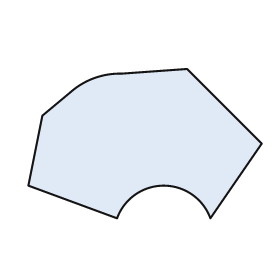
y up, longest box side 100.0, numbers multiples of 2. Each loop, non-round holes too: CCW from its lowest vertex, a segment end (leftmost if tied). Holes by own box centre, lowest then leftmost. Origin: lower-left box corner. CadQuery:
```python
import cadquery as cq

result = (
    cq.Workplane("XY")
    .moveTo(38.0, 0.0)
    .threePointArc((58.0, 14.0), (78.0, 0.0))
    .lineTo(100.0, 32.0)
    .lineTo(68.0, 64.0)
    .lineTo(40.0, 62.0)
    .threePointArc((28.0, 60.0), (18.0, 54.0))
    .lineTo(6.0, 44.0)
    .lineTo(0.0, 14.0)
    .close()
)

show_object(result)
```